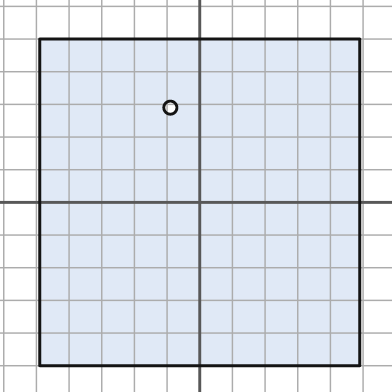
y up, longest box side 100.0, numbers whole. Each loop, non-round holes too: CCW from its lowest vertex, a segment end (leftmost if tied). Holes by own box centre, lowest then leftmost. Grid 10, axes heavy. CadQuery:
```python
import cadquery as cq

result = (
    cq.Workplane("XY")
    .moveTo(-49.0, -50.0)
    .lineTo(49.0, -50.0)
    .lineTo(49.0, 50.0)
    .lineTo(-49.0, 50.0)
    .close()
    .moveTo(-9.0, 29.0)
    .circle(2.0)
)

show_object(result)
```